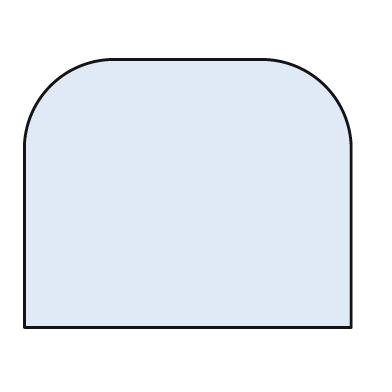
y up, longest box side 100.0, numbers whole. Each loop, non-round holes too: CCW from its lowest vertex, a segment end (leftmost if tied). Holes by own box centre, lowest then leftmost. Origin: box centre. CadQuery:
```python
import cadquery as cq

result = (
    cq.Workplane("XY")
    .moveTo(-50.0, -41.0)
    .lineTo(50.0, -41.0)
    .lineTo(50.0, 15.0)
    .threePointArc((42.0, 33.0), (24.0, 41.0))
    .lineTo(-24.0, 41.0)
    .threePointArc((-42.0, 33.0), (-50.0, 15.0))
    .close()
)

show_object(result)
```